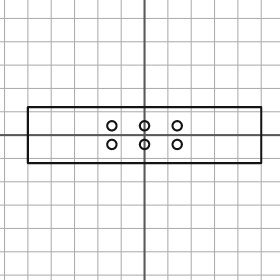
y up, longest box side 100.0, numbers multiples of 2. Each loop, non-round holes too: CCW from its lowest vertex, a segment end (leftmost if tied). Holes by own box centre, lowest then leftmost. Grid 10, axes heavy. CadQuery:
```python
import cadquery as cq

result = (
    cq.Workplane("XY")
    .moveTo(-50.0, -12.0)
    .lineTo(50.0, -12.0)
    .lineTo(50.0, 12.0)
    .lineTo(-50.0, 12.0)
    .close()
    .moveTo(-14.0, -4.0)
    .circle(2.0)
    .moveTo(0.0, -4.0)
    .circle(2.0)
    .moveTo(14.0, -4.0)
    .circle(2.0)
    .moveTo(-14.0, 4.0)
    .circle(2.0)
    .moveTo(0.0, 4.0)
    .circle(2.0)
    .moveTo(14.0, 4.0)
    .circle(2.0)
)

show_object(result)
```